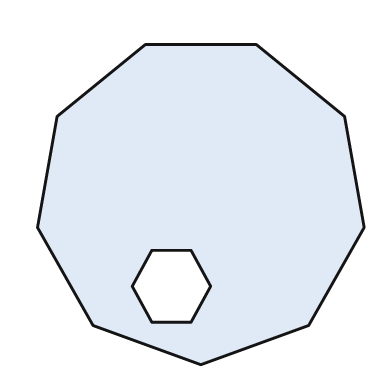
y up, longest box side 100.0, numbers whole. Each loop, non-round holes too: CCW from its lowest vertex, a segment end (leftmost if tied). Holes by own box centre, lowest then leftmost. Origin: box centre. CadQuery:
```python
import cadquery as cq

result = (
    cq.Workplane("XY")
    .moveTo(0.0, -49.0)
    .lineTo(33.0, -37.0)
    .lineTo(50.0, -7.0)
    .lineTo(44.0, 27.0)
    .lineTo(17.0, 49.0)
    .lineTo(-17.0, 49.0)
    .lineTo(-44.0, 27.0)
    .lineTo(-50.0, -7.0)
    .lineTo(-33.0, -37.0)
    .close()
    .moveTo(-15.0, -36.0)
    .lineTo(-3.0, -36.0)
    .lineTo(3.0, -25.0)
    .lineTo(-3.0, -14.0)
    .lineTo(-15.0, -14.0)
    .lineTo(-21.0, -25.0)
    .close()
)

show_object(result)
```